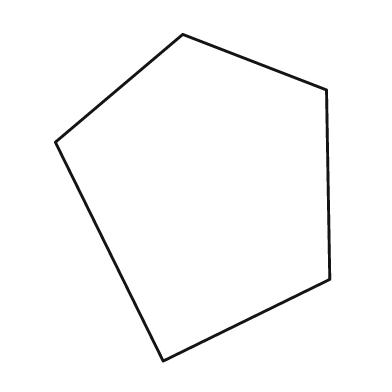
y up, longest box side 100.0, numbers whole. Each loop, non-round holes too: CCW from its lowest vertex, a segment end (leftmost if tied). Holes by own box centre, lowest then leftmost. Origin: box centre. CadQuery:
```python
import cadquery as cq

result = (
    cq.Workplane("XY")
    .moveTo(-9.0, -50.0)
    .lineTo(42.0, -25.0)
    .lineTo(41.0, 33.0)
    .lineTo(-3.0, 50.0)
    .lineTo(-42.0, 17.0)
    .close()
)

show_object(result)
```